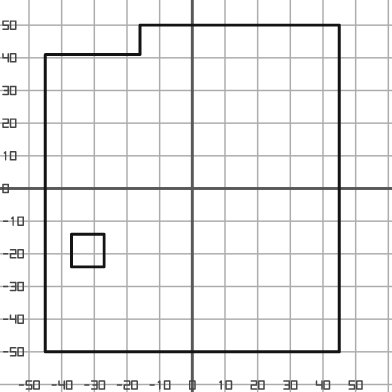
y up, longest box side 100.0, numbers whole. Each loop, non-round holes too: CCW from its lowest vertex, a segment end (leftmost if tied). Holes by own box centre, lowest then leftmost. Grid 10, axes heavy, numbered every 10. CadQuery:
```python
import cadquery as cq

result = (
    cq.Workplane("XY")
    .moveTo(-45.0, -50.0)
    .lineTo(45.0, -50.0)
    .lineTo(45.0, 50.0)
    .lineTo(-16.0, 50.0)
    .lineTo(-16.0, 41.0)
    .lineTo(-45.0, 41.0)
    .close()
    .moveTo(-37.0, -24.0)
    .lineTo(-27.0, -24.0)
    .lineTo(-27.0, -14.0)
    .lineTo(-37.0, -14.0)
    .close()
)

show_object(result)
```